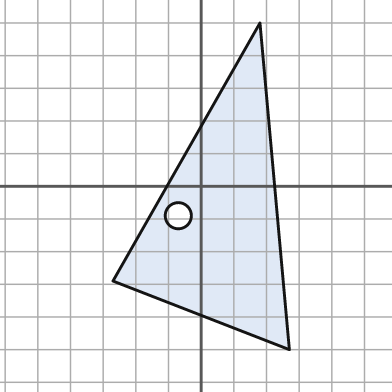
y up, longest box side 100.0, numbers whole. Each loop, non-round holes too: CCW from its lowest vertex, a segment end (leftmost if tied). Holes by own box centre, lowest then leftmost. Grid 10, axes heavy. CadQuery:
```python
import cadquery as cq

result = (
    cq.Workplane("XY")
    .moveTo(27.0, -50.0)
    .lineTo(18.0, 50.0)
    .lineTo(-27.0, -29.0)
    .close()
    .moveTo(-7.0, -9.0)
    .circle(4.0)
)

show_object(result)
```